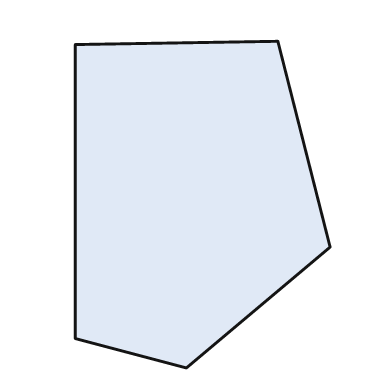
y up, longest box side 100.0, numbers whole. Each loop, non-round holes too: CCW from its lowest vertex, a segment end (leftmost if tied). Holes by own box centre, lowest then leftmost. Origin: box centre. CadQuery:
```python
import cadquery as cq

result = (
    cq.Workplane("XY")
    .moveTo(-5.0, -50.0)
    .lineTo(39.0, -13.0)
    .lineTo(23.0, 50.0)
    .lineTo(-39.0, 49.0)
    .lineTo(-39.0, -41.0)
    .close()
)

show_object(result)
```